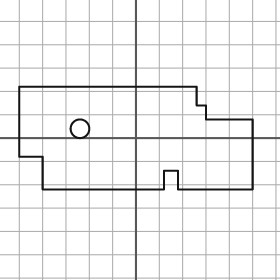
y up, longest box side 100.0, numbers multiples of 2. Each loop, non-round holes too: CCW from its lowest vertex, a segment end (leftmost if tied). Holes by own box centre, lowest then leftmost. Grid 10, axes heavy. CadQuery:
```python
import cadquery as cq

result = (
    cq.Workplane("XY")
    .moveTo(-40.0, -22.0)
    .lineTo(12.0, -22.0)
    .lineTo(12.0, -14.0)
    .lineTo(18.0, -14.0)
    .lineTo(18.0, -22.0)
    .lineTo(50.0, -22.0)
    .lineTo(50.0, 8.0)
    .lineTo(30.0, 8.0)
    .lineTo(30.0, 14.0)
    .lineTo(26.0, 14.0)
    .lineTo(26.0, 22.0)
    .lineTo(-50.0, 22.0)
    .lineTo(-50.0, -8.0)
    .lineTo(-40.0, -8.0)
    .close()
    .moveTo(-24.0, 4.0)
    .circle(4.0)
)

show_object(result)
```